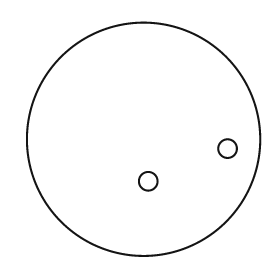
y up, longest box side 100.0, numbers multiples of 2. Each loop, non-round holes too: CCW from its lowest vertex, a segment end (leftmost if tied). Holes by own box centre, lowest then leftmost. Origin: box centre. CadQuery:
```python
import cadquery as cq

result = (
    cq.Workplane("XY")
    .moveTo(0.0, 0.0)
    .circle(50.0)
    .moveTo(2.0, -18.0)
    .circle(4.0)
    .moveTo(36.0, -4.0)
    .circle(4.0)
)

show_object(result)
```